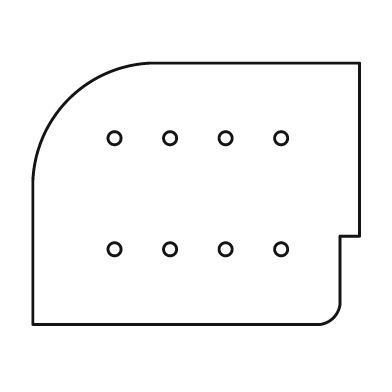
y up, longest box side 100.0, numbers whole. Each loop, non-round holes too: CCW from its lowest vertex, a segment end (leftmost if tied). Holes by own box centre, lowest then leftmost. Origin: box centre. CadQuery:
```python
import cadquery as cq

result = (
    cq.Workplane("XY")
    .moveTo(-50.0, -40.0)
    .lineTo(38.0, -40.0)
    .threePointArc((42.0, -38.0), (44.0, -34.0))
    .lineTo(44.0, -13.0)
    .lineTo(50.0, -13.0)
    .lineTo(50.0, 40.0)
    .lineTo(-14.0, 40.0)
    .threePointArc((-39.0, 29.0), (-50.0, 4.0))
    .close()
    .moveTo(-25.0, -17.0)
    .circle(2.0)
    .moveTo(-8.0, -17.0)
    .circle(2.0)
    .moveTo(9.0, -17.0)
    .circle(2.0)
    .moveTo(26.0, -17.0)
    .circle(2.0)
    .moveTo(-25.0, 17.0)
    .circle(2.0)
    .moveTo(-8.0, 17.0)
    .circle(2.0)
    .moveTo(9.0, 17.0)
    .circle(2.0)
    .moveTo(26.0, 17.0)
    .circle(2.0)
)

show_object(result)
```